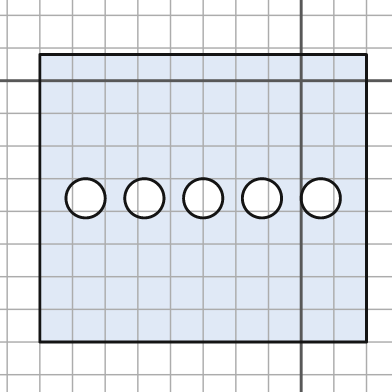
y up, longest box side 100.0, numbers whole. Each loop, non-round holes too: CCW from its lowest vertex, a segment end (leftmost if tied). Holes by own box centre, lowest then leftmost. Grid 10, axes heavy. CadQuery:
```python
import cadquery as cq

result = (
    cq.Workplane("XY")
    .moveTo(-80.0, -80.0)
    .lineTo(20.0, -80.0)
    .lineTo(20.0, 8.0)
    .lineTo(-80.0, 8.0)
    .close()
    .moveTo(-66.0, -36.0)
    .circle(6.0)
    .moveTo(-48.0, -36.0)
    .circle(6.0)
    .moveTo(-30.0, -36.0)
    .circle(6.0)
    .moveTo(-12.0, -36.0)
    .circle(6.0)
    .moveTo(6.0, -36.0)
    .circle(6.0)
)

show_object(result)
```